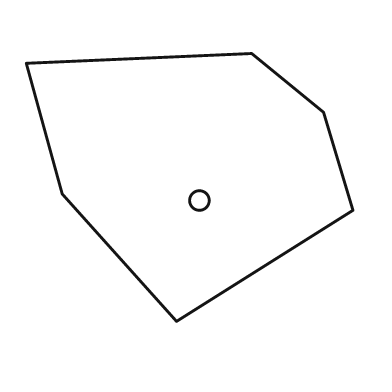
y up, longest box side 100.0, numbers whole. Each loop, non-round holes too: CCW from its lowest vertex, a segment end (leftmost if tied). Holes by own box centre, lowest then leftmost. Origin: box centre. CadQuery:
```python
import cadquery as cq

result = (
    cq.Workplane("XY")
    .moveTo(-4.0, -41.0)
    .lineTo(50.0, -7.0)
    .lineTo(41.0, 23.0)
    .lineTo(19.0, 41.0)
    .lineTo(-50.0, 38.0)
    .lineTo(-39.0, -2.0)
    .close()
    .moveTo(3.0, -4.0)
    .circle(3.0)
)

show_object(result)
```